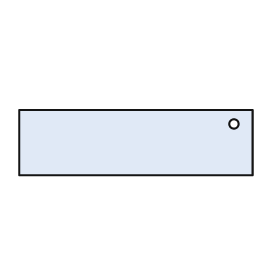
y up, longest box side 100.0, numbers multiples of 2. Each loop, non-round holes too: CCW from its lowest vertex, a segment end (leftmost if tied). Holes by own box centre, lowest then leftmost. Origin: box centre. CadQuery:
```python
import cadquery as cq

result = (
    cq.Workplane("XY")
    .moveTo(-50.0, -14.0)
    .lineTo(50.0, -14.0)
    .lineTo(50.0, 14.0)
    .lineTo(-50.0, 14.0)
    .close()
    .moveTo(42.0, 8.0)
    .circle(2.0)
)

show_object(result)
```